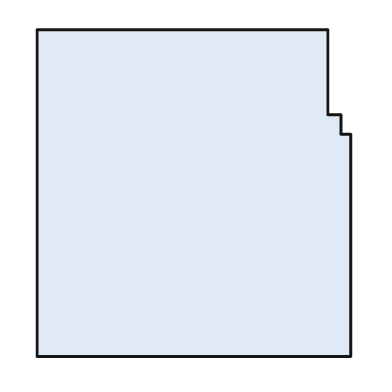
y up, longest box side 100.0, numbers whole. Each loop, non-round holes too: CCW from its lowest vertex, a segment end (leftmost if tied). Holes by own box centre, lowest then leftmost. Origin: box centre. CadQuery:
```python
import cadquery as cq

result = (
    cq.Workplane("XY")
    .moveTo(-48.0, -50.0)
    .lineTo(48.0, -50.0)
    .lineTo(48.0, 18.0)
    .lineTo(45.0, 18.0)
    .lineTo(45.0, 24.0)
    .lineTo(41.0, 24.0)
    .lineTo(41.0, 50.0)
    .lineTo(-48.0, 50.0)
    .close()
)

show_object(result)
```